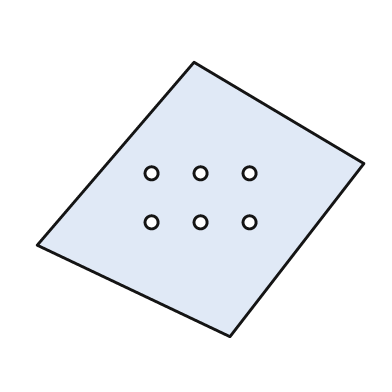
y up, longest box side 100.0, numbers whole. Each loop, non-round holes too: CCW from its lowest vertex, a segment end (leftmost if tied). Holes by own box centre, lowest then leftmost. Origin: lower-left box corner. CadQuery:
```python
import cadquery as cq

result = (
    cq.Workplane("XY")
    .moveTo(59.0, 0.0)
    .lineTo(100.0, 53.0)
    .lineTo(48.0, 84.0)
    .lineTo(0.0, 28.0)
    .close()
    .moveTo(35.0, 35.0)
    .circle(2.0)
    .moveTo(50.0, 35.0)
    .circle(2.0)
    .moveTo(65.0, 35.0)
    .circle(2.0)
    .moveTo(35.0, 50.0)
    .circle(2.0)
    .moveTo(50.0, 50.0)
    .circle(2.0)
    .moveTo(65.0, 50.0)
    .circle(2.0)
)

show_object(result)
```